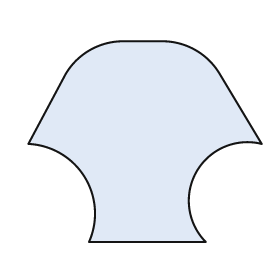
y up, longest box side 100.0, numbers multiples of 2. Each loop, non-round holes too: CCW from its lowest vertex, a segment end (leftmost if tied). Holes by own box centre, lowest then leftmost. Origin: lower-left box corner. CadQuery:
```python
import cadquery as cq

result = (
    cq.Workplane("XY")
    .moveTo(26.0, 0.0)
    .lineTo(76.0, 0.0)
    .threePointArc((72.0, 30.0), (100.0, 42.0))
    .lineTo(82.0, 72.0)
    .threePointArc((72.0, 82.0), (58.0, 86.0))
    .lineTo(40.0, 86.0)
    .threePointArc((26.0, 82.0), (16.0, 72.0))
    .lineTo(0.0, 42.0)
    .threePointArc((24.0, 28.0), (26.0, 0.0))
    .close()
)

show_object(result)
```